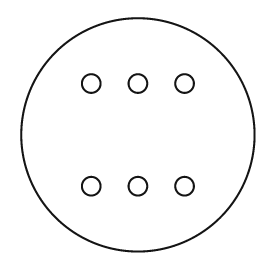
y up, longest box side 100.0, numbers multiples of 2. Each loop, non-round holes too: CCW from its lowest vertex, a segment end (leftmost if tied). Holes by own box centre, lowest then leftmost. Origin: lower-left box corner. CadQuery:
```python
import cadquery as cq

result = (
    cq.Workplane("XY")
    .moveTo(50.0, 50.0)
    .circle(50.0)
    .moveTo(30.0, 28.0)
    .circle(4.0)
    .moveTo(50.0, 28.0)
    .circle(4.0)
    .moveTo(70.0, 28.0)
    .circle(4.0)
    .moveTo(30.0, 72.0)
    .circle(4.0)
    .moveTo(50.0, 72.0)
    .circle(4.0)
    .moveTo(70.0, 72.0)
    .circle(4.0)
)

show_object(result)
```